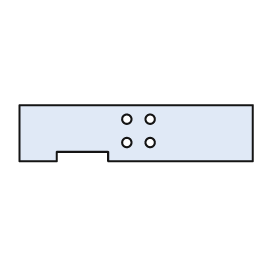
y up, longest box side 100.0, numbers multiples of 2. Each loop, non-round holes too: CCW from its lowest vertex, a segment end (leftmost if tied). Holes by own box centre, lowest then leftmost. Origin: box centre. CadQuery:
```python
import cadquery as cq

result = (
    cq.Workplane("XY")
    .moveTo(-50.0, -12.0)
    .lineTo(-34.0, -12.0)
    .lineTo(-34.0, -8.0)
    .lineTo(-12.0, -8.0)
    .lineTo(-12.0, -12.0)
    .lineTo(50.0, -12.0)
    .lineTo(50.0, 12.0)
    .lineTo(-50.0, 12.0)
    .close()
    .moveTo(-4.0, -4.0)
    .circle(2.0)
    .moveTo(6.0, -4.0)
    .circle(2.0)
    .moveTo(-4.0, 6.0)
    .circle(2.0)
    .moveTo(6.0, 6.0)
    .circle(2.0)
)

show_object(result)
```